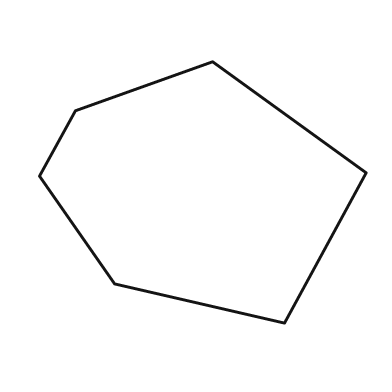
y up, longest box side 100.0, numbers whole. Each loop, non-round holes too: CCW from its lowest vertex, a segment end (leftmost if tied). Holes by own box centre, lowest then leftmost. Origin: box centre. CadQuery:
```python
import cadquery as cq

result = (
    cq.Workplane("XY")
    .moveTo(25.0, -40.0)
    .lineTo(50.0, 6.0)
    .lineTo(3.0, 40.0)
    .lineTo(-39.0, 25.0)
    .lineTo(-50.0, 5.0)
    .lineTo(-27.0, -28.0)
    .close()
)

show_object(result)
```